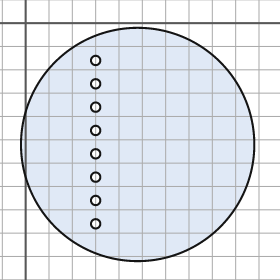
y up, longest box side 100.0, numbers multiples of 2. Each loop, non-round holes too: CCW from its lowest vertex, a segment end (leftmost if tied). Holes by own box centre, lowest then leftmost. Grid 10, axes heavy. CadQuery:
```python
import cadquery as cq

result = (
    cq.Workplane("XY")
    .moveTo(48.0, -52.0)
    .circle(50.0)
    .moveTo(30.0, -86.0)
    .circle(2.0)
    .moveTo(30.0, -76.0)
    .circle(2.0)
    .moveTo(30.0, -66.0)
    .circle(2.0)
    .moveTo(30.0, -56.0)
    .circle(2.0)
    .moveTo(30.0, -46.0)
    .circle(2.0)
    .moveTo(30.0, -36.0)
    .circle(2.0)
    .moveTo(30.0, -26.0)
    .circle(2.0)
    .moveTo(30.0, -16.0)
    .circle(2.0)
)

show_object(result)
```